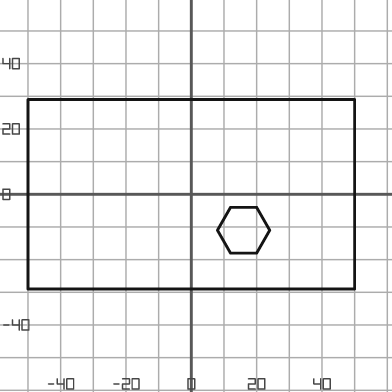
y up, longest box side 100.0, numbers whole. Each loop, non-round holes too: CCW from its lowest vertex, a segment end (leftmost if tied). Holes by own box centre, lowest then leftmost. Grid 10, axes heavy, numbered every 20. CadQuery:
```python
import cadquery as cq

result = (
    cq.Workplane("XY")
    .moveTo(-50.0, -29.0)
    .lineTo(50.0, -29.0)
    .lineTo(50.0, 29.0)
    .lineTo(-50.0, 29.0)
    .close()
    .moveTo(12.0, -18.0)
    .lineTo(20.0, -18.0)
    .lineTo(24.0, -11.0)
    .lineTo(20.0, -4.0)
    .lineTo(12.0, -4.0)
    .lineTo(8.0, -11.0)
    .close()
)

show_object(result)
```